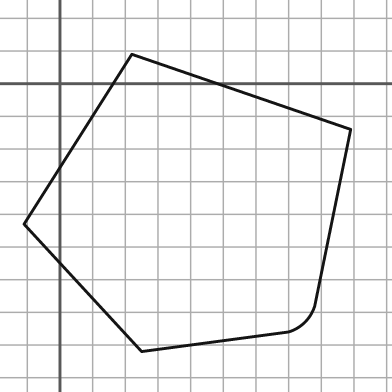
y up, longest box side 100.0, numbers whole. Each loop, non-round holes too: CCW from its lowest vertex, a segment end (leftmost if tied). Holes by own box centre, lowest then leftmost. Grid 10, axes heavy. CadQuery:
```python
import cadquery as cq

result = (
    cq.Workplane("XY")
    .moveTo(25.0, -82.0)
    .lineTo(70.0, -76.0)
    .threePointArc((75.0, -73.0), (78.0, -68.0))
    .lineTo(89.0, -14.0)
    .lineTo(22.0, 9.0)
    .lineTo(-11.0, -43.0)
    .close()
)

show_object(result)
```